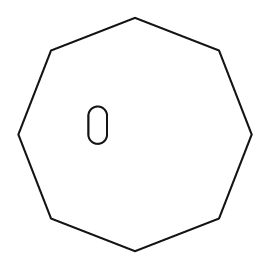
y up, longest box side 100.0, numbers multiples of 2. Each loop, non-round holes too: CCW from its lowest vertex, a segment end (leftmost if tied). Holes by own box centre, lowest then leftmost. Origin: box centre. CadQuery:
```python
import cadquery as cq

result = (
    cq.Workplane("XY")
    .moveTo(0.0, -50.0)
    .lineTo(36.0, -36.0)
    .lineTo(50.0, 0.0)
    .lineTo(36.0, 36.0)
    .lineTo(0.0, 50.0)
    .lineTo(-36.0, 36.0)
    .lineTo(-50.0, 0.0)
    .lineTo(-36.0, -36.0)
    .close()
    .moveTo(-20.0, 0.0)
    .threePointArc((-16.0, -4.0), (-12.0, 0.0))
    .lineTo(-12.0, 8.0)
    .threePointArc((-16.0, 12.0), (-20.0, 8.0))
    .close()
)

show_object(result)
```